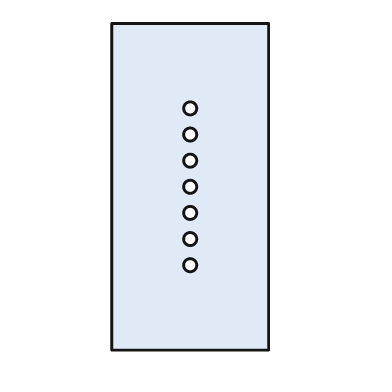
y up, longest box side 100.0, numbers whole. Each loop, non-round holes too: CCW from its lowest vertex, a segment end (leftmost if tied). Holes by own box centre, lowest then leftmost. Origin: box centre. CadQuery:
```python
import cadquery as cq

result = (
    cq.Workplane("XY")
    .moveTo(-24.0, -50.0)
    .lineTo(24.0, -50.0)
    .lineTo(24.0, 50.0)
    .lineTo(-24.0, 50.0)
    .close()
    .moveTo(0.0, -24.0)
    .circle(2.0)
    .moveTo(0.0, -16.0)
    .circle(2.0)
    .moveTo(0.0, -8.0)
    .circle(2.0)
    .moveTo(0.0, 0.0)
    .circle(2.0)
    .moveTo(0.0, 8.0)
    .circle(2.0)
    .moveTo(0.0, 16.0)
    .circle(2.0)
    .moveTo(0.0, 24.0)
    .circle(2.0)
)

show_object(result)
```